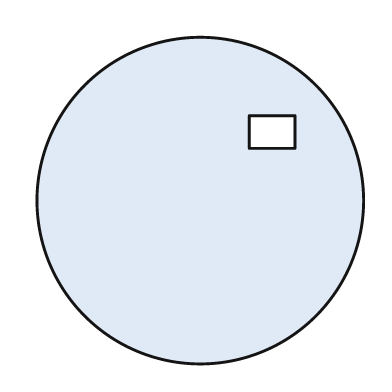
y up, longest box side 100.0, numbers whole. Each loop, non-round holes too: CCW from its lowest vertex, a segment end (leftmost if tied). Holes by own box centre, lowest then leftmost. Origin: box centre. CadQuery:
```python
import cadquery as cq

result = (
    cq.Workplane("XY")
    .moveTo(0.0, 0.0)
    .circle(50.0)
    .moveTo(15.0, 16.0)
    .lineTo(29.0, 16.0)
    .lineTo(29.0, 26.0)
    .lineTo(15.0, 26.0)
    .close()
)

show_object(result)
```